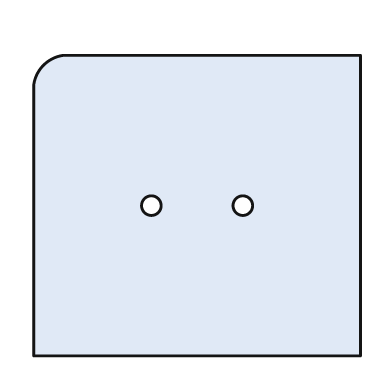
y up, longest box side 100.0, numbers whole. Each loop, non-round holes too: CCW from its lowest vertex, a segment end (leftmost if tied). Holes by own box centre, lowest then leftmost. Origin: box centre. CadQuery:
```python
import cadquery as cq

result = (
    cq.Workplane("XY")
    .moveTo(-50.0, -46.0)
    .lineTo(50.0, -46.0)
    .lineTo(50.0, 46.0)
    .lineTo(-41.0, 46.0)
    .threePointArc((-47.0, 43.0), (-50.0, 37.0))
    .close()
    .moveTo(-14.0, 0.0)
    .circle(3.0)
    .moveTo(14.0, 0.0)
    .circle(3.0)
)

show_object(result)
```